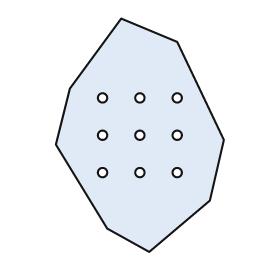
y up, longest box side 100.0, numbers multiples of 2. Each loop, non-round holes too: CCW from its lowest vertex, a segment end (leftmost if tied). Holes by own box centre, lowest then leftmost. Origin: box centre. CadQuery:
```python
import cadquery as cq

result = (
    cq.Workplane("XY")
    .moveTo(4.0, -50.0)
    .lineTo(30.0, -28.0)
    .lineTo(36.0, -2.0)
    .lineTo(16.0, 40.0)
    .lineTo(-8.0, 50.0)
    .lineTo(-30.0, 20.0)
    .lineTo(-36.0, -4.0)
    .lineTo(-14.0, -40.0)
    .close()
    .moveTo(-16.0, -16.0)
    .circle(2.0)
    .moveTo(0.0, -16.0)
    .circle(2.0)
    .moveTo(16.0, -16.0)
    .circle(2.0)
    .moveTo(-16.0, 0.0)
    .circle(2.0)
    .moveTo(0.0, 0.0)
    .circle(2.0)
    .moveTo(16.0, 0.0)
    .circle(2.0)
    .moveTo(-16.0, 16.0)
    .circle(2.0)
    .moveTo(0.0, 16.0)
    .circle(2.0)
    .moveTo(16.0, 16.0)
    .circle(2.0)
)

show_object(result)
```